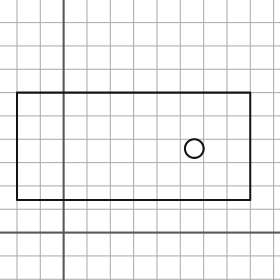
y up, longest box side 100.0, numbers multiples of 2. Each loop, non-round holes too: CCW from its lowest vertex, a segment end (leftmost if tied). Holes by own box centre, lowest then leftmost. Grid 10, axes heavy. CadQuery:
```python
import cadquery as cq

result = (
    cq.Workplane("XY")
    .moveTo(-20.0, 14.0)
    .lineTo(80.0, 14.0)
    .lineTo(80.0, 60.0)
    .lineTo(-20.0, 60.0)
    .close()
    .moveTo(56.0, 36.0)
    .circle(4.0)
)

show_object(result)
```